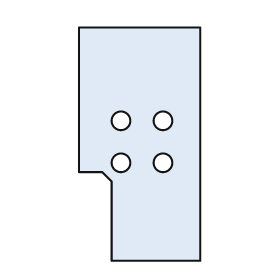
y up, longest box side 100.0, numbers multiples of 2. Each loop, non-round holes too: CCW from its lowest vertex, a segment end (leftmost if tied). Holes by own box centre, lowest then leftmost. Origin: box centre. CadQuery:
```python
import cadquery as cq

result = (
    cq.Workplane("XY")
    .moveTo(-12.0, -50.0)
    .lineTo(26.0, -50.0)
    .lineTo(26.0, 50.0)
    .lineTo(-26.0, 50.0)
    .lineTo(-26.0, -12.0)
    .lineTo(-16.0, -12.0)
    .lineTo(-12.0, -16.0)
    .close()
    .moveTo(-8.0, -8.0)
    .circle(4.0)
    .moveTo(10.0, -8.0)
    .circle(4.0)
    .moveTo(-8.0, 10.0)
    .circle(4.0)
    .moveTo(10.0, 10.0)
    .circle(4.0)
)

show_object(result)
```